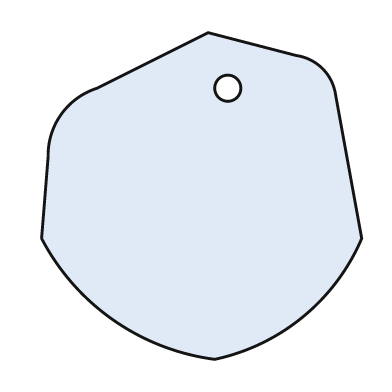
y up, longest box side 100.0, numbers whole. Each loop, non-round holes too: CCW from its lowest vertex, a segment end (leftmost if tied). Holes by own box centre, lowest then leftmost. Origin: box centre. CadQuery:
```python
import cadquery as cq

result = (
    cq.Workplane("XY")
    .moveTo(4.0, -50.0)
    .threePointArc((31.0, -37.0), (49.0, -13.0))
    .lineTo(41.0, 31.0)
    .threePointArc((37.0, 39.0), (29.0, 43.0))
    .lineTo(2.0, 50.0)
    .lineTo(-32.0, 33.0)
    .threePointArc((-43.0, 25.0), (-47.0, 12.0))
    .lineTo(-49.0, -13.0)
    .threePointArc((-27.0, -38.0), (4.0, -50.0))
    .close()
    .moveTo(8.0, 33.0)
    .circle(4.0)
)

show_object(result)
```